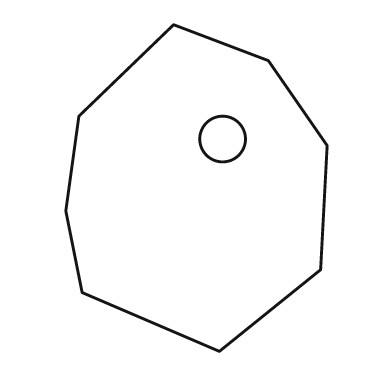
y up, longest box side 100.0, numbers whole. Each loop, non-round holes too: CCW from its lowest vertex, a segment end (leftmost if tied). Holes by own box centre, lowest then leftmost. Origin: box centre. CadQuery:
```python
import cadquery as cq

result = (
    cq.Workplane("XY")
    .moveTo(7.0, -50.0)
    .lineTo(38.0, -25.0)
    .lineTo(40.0, 13.0)
    .lineTo(22.0, 39.0)
    .lineTo(-7.0, 50.0)
    .lineTo(-36.0, 22.0)
    .lineTo(-40.0, -7.0)
    .lineTo(-35.0, -32.0)
    .close()
    .moveTo(8.0, 15.0)
    .circle(7.0)
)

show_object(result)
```